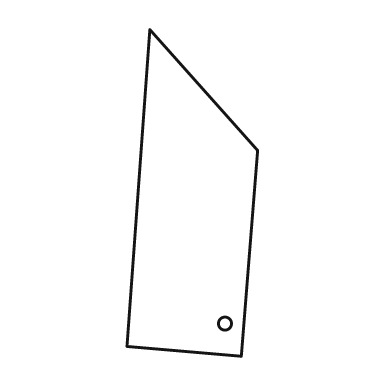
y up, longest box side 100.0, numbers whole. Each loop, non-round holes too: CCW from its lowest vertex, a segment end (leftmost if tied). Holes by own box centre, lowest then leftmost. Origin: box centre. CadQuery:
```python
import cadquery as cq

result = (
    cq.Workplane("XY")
    .moveTo(15.0, -50.0)
    .lineTo(20.0, 13.0)
    .lineTo(-13.0, 50.0)
    .lineTo(-20.0, -47.0)
    .close()
    .moveTo(10.0, -40.0)
    .circle(2.0)
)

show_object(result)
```